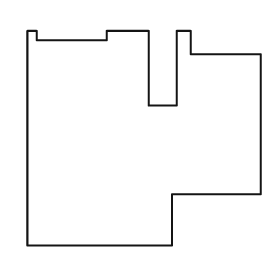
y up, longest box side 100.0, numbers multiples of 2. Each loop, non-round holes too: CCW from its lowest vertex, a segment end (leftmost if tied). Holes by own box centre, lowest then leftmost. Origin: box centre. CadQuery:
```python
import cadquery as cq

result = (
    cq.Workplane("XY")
    .moveTo(-50.0, -46.0)
    .lineTo(12.0, -46.0)
    .lineTo(12.0, -24.0)
    .lineTo(50.0, -24.0)
    .lineTo(50.0, 36.0)
    .lineTo(20.0, 36.0)
    .lineTo(20.0, 46.0)
    .lineTo(14.0, 46.0)
    .lineTo(14.0, 14.0)
    .lineTo(2.0, 14.0)
    .lineTo(2.0, 46.0)
    .lineTo(-16.0, 46.0)
    .lineTo(-16.0, 42.0)
    .lineTo(-46.0, 42.0)
    .lineTo(-46.0, 46.0)
    .lineTo(-50.0, 46.0)
    .close()
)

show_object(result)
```